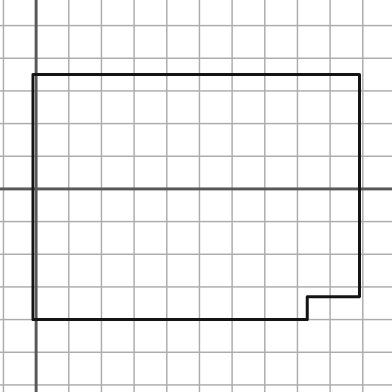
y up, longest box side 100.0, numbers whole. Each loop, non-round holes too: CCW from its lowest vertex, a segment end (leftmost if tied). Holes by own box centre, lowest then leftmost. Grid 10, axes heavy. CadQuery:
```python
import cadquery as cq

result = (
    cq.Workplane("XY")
    .moveTo(-1.0, -40.0)
    .lineTo(83.0, -40.0)
    .lineTo(83.0, -33.0)
    .lineTo(99.0, -33.0)
    .lineTo(99.0, 35.0)
    .lineTo(-1.0, 35.0)
    .close()
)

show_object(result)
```